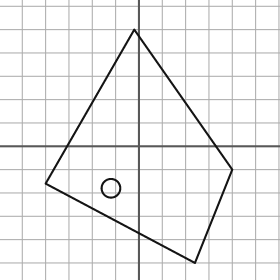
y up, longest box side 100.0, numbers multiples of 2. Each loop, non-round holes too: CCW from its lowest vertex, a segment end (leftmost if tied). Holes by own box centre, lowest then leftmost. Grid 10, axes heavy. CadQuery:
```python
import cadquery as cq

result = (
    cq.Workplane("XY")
    .moveTo(24.0, -50.0)
    .lineTo(40.0, -10.0)
    .lineTo(-2.0, 50.0)
    .lineTo(-40.0, -16.0)
    .close()
    .moveTo(-12.0, -18.0)
    .circle(4.0)
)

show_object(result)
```